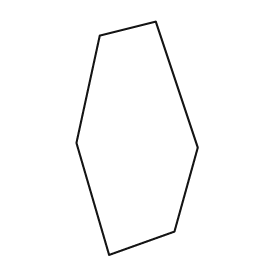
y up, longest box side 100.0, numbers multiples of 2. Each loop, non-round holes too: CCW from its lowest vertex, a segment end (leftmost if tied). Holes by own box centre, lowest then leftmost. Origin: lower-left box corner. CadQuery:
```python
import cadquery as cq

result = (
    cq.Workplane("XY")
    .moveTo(14.0, 0.0)
    .lineTo(42.0, 10.0)
    .lineTo(52.0, 46.0)
    .lineTo(34.0, 100.0)
    .lineTo(10.0, 94.0)
    .lineTo(0.0, 48.0)
    .close()
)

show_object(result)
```